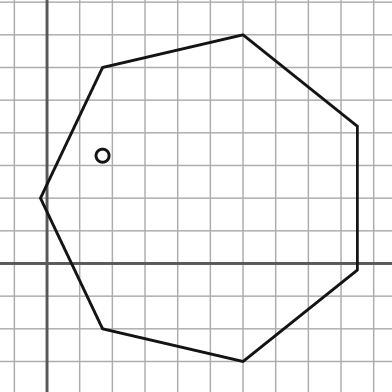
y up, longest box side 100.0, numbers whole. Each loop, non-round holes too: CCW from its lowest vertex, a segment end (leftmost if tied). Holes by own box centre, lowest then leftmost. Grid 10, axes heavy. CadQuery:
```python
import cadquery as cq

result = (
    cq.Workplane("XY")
    .moveTo(60.0, -30.0)
    .lineTo(95.0, -2.0)
    .lineTo(95.0, 42.0)
    .lineTo(60.0, 70.0)
    .lineTo(17.0, 60.0)
    .lineTo(-2.0, 20.0)
    .lineTo(17.0, -20.0)
    .close()
    .moveTo(17.0, 33.0)
    .circle(2.0)
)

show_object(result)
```